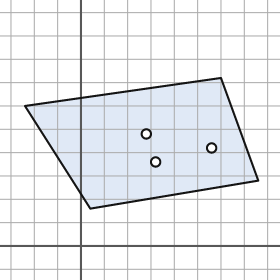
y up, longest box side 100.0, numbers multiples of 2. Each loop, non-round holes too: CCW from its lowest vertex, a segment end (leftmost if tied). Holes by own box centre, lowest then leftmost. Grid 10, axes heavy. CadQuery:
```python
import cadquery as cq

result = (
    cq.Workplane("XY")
    .moveTo(4.0, 16.0)
    .lineTo(76.0, 28.0)
    .lineTo(60.0, 72.0)
    .lineTo(-24.0, 60.0)
    .close()
    .moveTo(32.0, 36.0)
    .circle(2.0)
    .moveTo(56.0, 42.0)
    .circle(2.0)
    .moveTo(28.0, 48.0)
    .circle(2.0)
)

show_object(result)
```